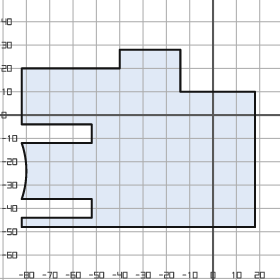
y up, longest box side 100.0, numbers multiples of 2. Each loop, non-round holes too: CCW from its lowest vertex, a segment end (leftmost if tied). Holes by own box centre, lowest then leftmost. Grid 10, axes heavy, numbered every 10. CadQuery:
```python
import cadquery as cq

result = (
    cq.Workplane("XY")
    .moveTo(-82.0, -48.0)
    .lineTo(18.0, -48.0)
    .lineTo(18.0, 10.0)
    .lineTo(-14.0, 10.0)
    .lineTo(-14.0, 28.0)
    .lineTo(-40.0, 28.0)
    .lineTo(-40.0, 20.0)
    .lineTo(-82.0, 20.0)
    .lineTo(-82.0, -4.0)
    .lineTo(-52.0, -4.0)
    .lineTo(-52.0, -12.0)
    .lineTo(-82.0, -12.0)
    .threePointArc((-80.0, -24.0), (-82.0, -36.0))
    .lineTo(-52.0, -36.0)
    .lineTo(-52.0, -44.0)
    .lineTo(-82.0, -44.0)
    .close()
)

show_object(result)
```